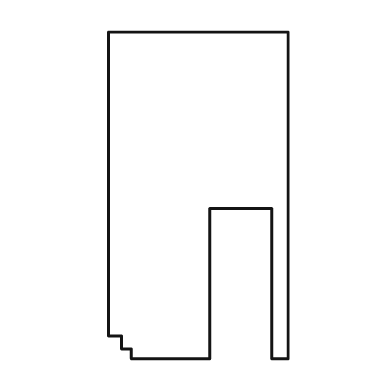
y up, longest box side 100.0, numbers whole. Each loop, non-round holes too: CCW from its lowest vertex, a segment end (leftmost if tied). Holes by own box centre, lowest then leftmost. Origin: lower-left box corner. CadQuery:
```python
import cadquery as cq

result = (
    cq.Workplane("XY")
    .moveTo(7.0, 0.0)
    .lineTo(31.0, 0.0)
    .lineTo(31.0, 46.0)
    .lineTo(50.0, 46.0)
    .lineTo(50.0, 0.0)
    .lineTo(55.0, 0.0)
    .lineTo(55.0, 100.0)
    .lineTo(0.0, 100.0)
    .lineTo(0.0, 7.0)
    .lineTo(4.0, 7.0)
    .lineTo(4.0, 3.0)
    .lineTo(7.0, 3.0)
    .close()
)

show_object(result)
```